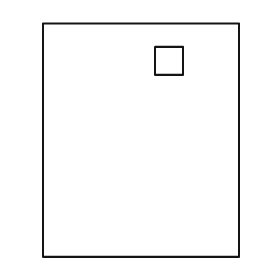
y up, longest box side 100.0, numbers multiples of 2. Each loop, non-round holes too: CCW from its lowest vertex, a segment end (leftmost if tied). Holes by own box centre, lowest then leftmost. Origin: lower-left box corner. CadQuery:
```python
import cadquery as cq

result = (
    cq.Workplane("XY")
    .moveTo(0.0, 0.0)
    .lineTo(84.0, 0.0)
    .lineTo(84.0, 100.0)
    .lineTo(0.0, 100.0)
    .close()
    .moveTo(48.0, 78.0)
    .lineTo(60.0, 78.0)
    .lineTo(60.0, 90.0)
    .lineTo(48.0, 90.0)
    .close()
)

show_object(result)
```